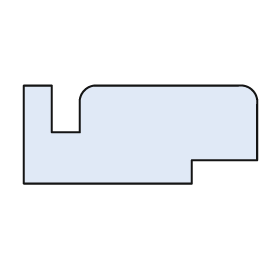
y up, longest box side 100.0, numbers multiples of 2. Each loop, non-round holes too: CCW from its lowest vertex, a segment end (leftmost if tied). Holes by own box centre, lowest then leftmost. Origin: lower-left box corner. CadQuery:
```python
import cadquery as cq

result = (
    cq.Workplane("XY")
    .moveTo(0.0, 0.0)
    .lineTo(72.0, 0.0)
    .lineTo(72.0, 10.0)
    .lineTo(100.0, 10.0)
    .lineTo(100.0, 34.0)
    .threePointArc((98.0, 40.0), (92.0, 42.0))
    .lineTo(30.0, 42.0)
    .threePointArc((26.0, 40.0), (24.0, 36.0))
    .lineTo(24.0, 22.0)
    .lineTo(12.0, 22.0)
    .lineTo(12.0, 42.0)
    .lineTo(0.0, 42.0)
    .close()
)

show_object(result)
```